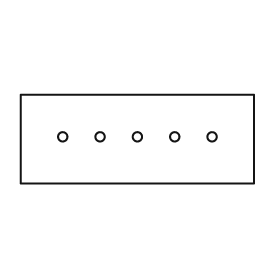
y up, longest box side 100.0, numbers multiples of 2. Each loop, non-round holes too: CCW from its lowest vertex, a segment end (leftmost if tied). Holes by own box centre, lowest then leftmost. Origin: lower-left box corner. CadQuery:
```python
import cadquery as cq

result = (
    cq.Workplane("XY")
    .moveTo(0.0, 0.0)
    .lineTo(100.0, 0.0)
    .lineTo(100.0, 38.0)
    .lineTo(0.0, 38.0)
    .close()
    .moveTo(18.0, 20.0)
    .circle(2.0)
    .moveTo(34.0, 20.0)
    .circle(2.0)
    .moveTo(50.0, 20.0)
    .circle(2.0)
    .moveTo(66.0, 20.0)
    .circle(2.0)
    .moveTo(82.0, 20.0)
    .circle(2.0)
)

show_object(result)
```